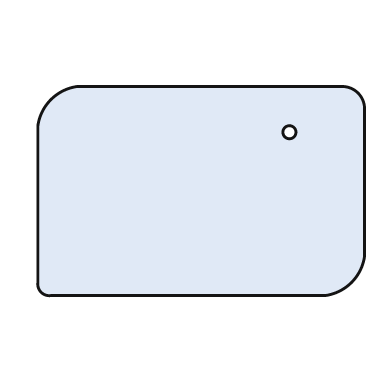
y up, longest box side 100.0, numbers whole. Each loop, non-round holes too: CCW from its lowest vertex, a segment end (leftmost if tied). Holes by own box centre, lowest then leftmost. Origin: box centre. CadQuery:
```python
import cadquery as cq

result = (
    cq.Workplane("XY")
    .moveTo(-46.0, -32.0)
    .lineTo(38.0, -32.0)
    .threePointArc((46.0, -28.0), (50.0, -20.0))
    .lineTo(50.0, 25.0)
    .threePointArc((48.0, 30.0), (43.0, 32.0))
    .lineTo(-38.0, 32.0)
    .threePointArc((-46.0, 28.0), (-50.0, 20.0))
    .lineTo(-50.0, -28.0)
    .threePointArc((-49.0, -31.0), (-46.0, -32.0))
    .close()
    .moveTo(27.0, 18.0)
    .circle(2.0)
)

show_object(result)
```